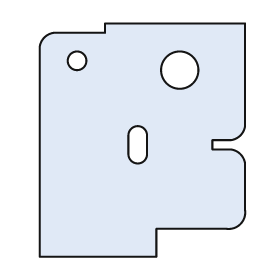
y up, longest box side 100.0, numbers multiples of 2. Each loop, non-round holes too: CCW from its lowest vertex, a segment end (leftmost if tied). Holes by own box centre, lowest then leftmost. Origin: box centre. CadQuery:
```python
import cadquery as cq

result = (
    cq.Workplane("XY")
    .moveTo(-44.0, -50.0)
    .lineTo(6.0, -50.0)
    .lineTo(6.0, -38.0)
    .lineTo(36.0, -38.0)
    .threePointArc((42.0, -36.0), (44.0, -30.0))
    .lineTo(44.0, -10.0)
    .threePointArc((42.0, -6.0), (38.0, -4.0))
    .lineTo(30.0, -4.0)
    .lineTo(30.0, 0.0)
    .lineTo(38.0, 0.0)
    .threePointArc((42.0, 2.0), (44.0, 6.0))
    .lineTo(44.0, 50.0)
    .lineTo(-16.0, 50.0)
    .lineTo(-16.0, 46.0)
    .lineTo(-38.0, 46.0)
    .threePointArc((-42.0, 44.0), (-44.0, 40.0))
    .close()
    .moveTo(-6.0, -6.0)
    .threePointArc((-2.0, -10.0), (2.0, -6.0))
    .lineTo(2.0, 2.0)
    .threePointArc((-2.0, 6.0), (-6.0, 2.0))
    .close()
    .moveTo(16.0, 30.0)
    .circle(8.0)
    .moveTo(-28.0, 34.0)
    .circle(4.0)
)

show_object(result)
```